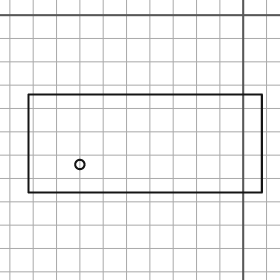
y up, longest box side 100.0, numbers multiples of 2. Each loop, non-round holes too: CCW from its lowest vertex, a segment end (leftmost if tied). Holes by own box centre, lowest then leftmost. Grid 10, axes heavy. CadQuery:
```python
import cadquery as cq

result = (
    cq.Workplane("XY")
    .moveTo(-92.0, -76.0)
    .lineTo(8.0, -76.0)
    .lineTo(8.0, -34.0)
    .lineTo(-92.0, -34.0)
    .close()
    .moveTo(-70.0, -64.0)
    .circle(2.0)
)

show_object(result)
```